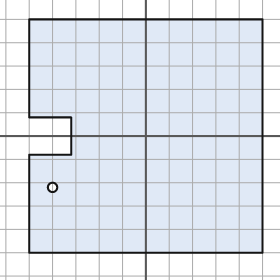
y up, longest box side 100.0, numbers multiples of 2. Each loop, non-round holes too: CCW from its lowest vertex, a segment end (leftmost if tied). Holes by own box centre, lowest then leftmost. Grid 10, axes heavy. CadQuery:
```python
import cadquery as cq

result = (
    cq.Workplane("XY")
    .moveTo(-50.0, -50.0)
    .lineTo(50.0, -50.0)
    .lineTo(50.0, 50.0)
    .lineTo(-50.0, 50.0)
    .lineTo(-50.0, 8.0)
    .lineTo(-32.0, 8.0)
    .lineTo(-32.0, -8.0)
    .lineTo(-50.0, -8.0)
    .close()
    .moveTo(-40.0, -22.0)
    .circle(2.0)
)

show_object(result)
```